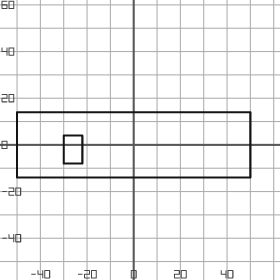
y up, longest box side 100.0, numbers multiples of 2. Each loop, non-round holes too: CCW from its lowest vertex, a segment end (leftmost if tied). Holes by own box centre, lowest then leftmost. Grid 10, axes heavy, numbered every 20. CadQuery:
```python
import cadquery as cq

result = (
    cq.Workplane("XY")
    .moveTo(-50.0, -14.0)
    .lineTo(50.0, -14.0)
    .lineTo(50.0, 14.0)
    .lineTo(-50.0, 14.0)
    .close()
    .moveTo(-30.0, -8.0)
    .lineTo(-22.0, -8.0)
    .lineTo(-22.0, 4.0)
    .lineTo(-30.0, 4.0)
    .close()
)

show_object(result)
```